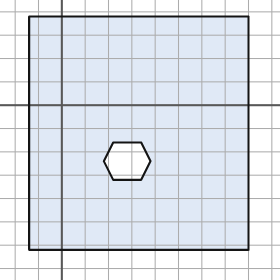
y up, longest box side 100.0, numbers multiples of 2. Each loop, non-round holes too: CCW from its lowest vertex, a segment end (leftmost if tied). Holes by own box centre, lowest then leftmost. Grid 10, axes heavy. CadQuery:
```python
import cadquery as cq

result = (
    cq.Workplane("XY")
    .moveTo(-14.0, -62.0)
    .lineTo(80.0, -62.0)
    .lineTo(80.0, 38.0)
    .lineTo(-14.0, 38.0)
    .close()
    .moveTo(22.0, -32.0)
    .lineTo(34.0, -32.0)
    .lineTo(38.0, -24.0)
    .lineTo(34.0, -16.0)
    .lineTo(22.0, -16.0)
    .lineTo(18.0, -24.0)
    .close()
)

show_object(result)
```